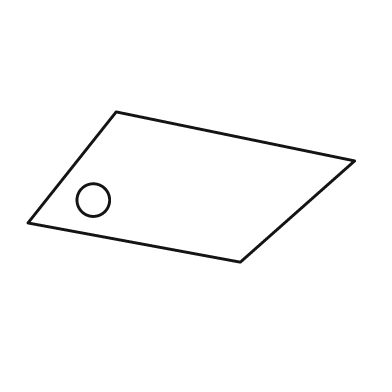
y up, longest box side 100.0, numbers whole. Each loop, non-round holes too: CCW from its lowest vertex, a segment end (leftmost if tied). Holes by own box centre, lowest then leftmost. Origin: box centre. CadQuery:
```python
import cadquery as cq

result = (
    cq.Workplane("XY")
    .moveTo(15.0, -23.0)
    .lineTo(50.0, 8.0)
    .lineTo(-23.0, 23.0)
    .lineTo(-50.0, -11.0)
    .close()
    .moveTo(-30.0, -4.0)
    .circle(5.0)
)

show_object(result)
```